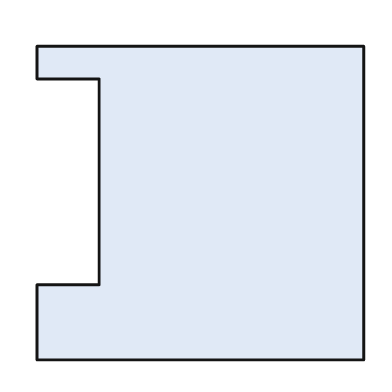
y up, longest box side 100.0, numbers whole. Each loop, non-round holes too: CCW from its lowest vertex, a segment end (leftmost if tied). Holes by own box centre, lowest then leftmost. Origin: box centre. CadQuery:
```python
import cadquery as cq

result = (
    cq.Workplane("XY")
    .moveTo(-50.0, -48.0)
    .lineTo(50.0, -48.0)
    .lineTo(50.0, 48.0)
    .lineTo(-50.0, 48.0)
    .lineTo(-50.0, 38.0)
    .lineTo(-31.0, 38.0)
    .lineTo(-31.0, -25.0)
    .lineTo(-50.0, -25.0)
    .close()
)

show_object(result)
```